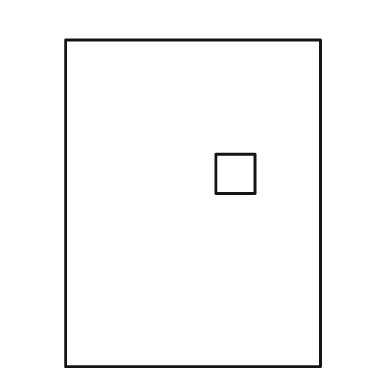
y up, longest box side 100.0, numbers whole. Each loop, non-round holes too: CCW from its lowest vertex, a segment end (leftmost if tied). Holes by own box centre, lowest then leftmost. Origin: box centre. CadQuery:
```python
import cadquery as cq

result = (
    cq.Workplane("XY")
    .moveTo(-39.0, -50.0)
    .lineTo(39.0, -50.0)
    .lineTo(39.0, 50.0)
    .lineTo(-39.0, 50.0)
    .close()
    .moveTo(7.0, 3.0)
    .lineTo(19.0, 3.0)
    .lineTo(19.0, 15.0)
    .lineTo(7.0, 15.0)
    .close()
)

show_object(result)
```